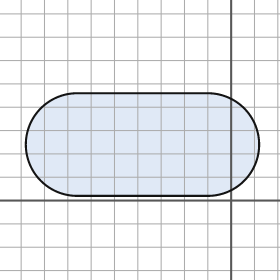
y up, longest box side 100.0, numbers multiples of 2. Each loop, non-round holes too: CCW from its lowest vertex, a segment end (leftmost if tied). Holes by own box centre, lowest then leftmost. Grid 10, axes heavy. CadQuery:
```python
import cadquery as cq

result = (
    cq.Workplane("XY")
    .moveTo(-66.0, 2.0)
    .lineTo(-10.0, 2.0)
    .threePointArc((12.0, 24.0), (-10.0, 46.0))
    .lineTo(-66.0, 46.0)
    .threePointArc((-88.0, 24.0), (-66.0, 2.0))
    .close()
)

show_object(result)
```